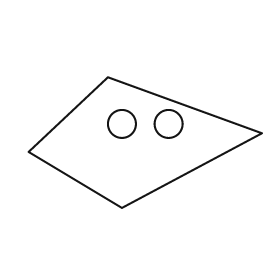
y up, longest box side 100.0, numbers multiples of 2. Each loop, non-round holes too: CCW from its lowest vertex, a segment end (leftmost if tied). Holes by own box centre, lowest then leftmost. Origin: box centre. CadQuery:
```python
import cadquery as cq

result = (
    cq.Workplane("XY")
    .moveTo(-10.0, -28.0)
    .lineTo(50.0, 4.0)
    .lineTo(-16.0, 28.0)
    .lineTo(-50.0, -4.0)
    .close()
    .moveTo(-10.0, 8.0)
    .circle(6.0)
    .moveTo(10.0, 8.0)
    .circle(6.0)
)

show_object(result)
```